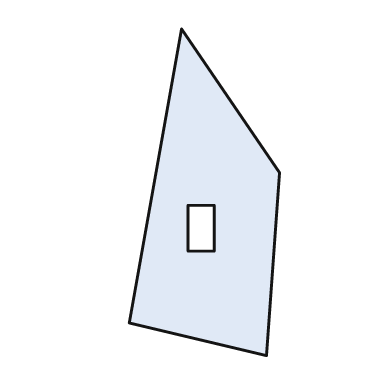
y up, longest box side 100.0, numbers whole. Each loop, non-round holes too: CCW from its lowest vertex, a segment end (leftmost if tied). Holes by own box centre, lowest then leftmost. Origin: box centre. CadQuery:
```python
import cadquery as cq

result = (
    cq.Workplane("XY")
    .moveTo(19.0, -50.0)
    .lineTo(23.0, 6.0)
    .lineTo(-7.0, 50.0)
    .lineTo(-23.0, -40.0)
    .close()
    .moveTo(-5.0, -18.0)
    .lineTo(3.0, -18.0)
    .lineTo(3.0, -4.0)
    .lineTo(-5.0, -4.0)
    .close()
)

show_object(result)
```